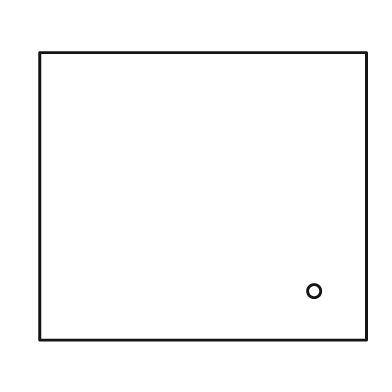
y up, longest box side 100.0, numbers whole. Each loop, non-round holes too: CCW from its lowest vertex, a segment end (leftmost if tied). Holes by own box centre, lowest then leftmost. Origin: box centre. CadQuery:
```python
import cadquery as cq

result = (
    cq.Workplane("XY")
    .moveTo(-50.0, -44.0)
    .lineTo(50.0, -44.0)
    .lineTo(50.0, 44.0)
    .lineTo(-50.0, 44.0)
    .close()
    .moveTo(34.0, -29.0)
    .circle(2.0)
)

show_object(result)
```